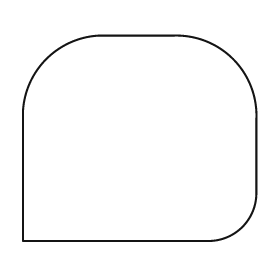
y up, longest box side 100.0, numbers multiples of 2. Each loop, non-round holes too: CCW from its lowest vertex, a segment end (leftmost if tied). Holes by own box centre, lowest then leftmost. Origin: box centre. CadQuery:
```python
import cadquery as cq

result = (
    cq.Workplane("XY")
    .moveTo(-50.0, -44.0)
    .lineTo(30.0, -44.0)
    .threePointArc((44.0, -38.0), (50.0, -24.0))
    .lineTo(50.0, 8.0)
    .threePointArc((40.0, 34.0), (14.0, 44.0))
    .lineTo(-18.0, 44.0)
    .threePointArc((-40.0, 34.0), (-50.0, 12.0))
    .close()
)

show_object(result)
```